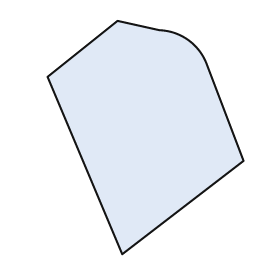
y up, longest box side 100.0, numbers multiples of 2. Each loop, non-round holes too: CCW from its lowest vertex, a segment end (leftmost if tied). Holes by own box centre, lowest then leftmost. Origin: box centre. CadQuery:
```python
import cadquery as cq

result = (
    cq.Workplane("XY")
    .moveTo(-10.0, -50.0)
    .lineTo(42.0, -10.0)
    .lineTo(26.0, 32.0)
    .threePointArc((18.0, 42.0), (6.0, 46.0))
    .lineTo(-12.0, 50.0)
    .lineTo(-42.0, 26.0)
    .close()
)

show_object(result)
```